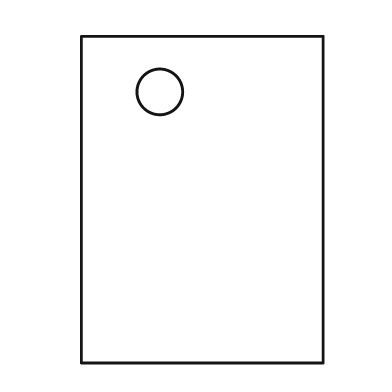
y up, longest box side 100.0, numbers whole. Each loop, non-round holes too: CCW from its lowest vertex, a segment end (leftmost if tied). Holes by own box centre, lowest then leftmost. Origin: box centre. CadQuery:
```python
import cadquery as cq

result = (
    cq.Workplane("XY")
    .moveTo(-37.0, -50.0)
    .lineTo(37.0, -50.0)
    .lineTo(37.0, 50.0)
    .lineTo(-37.0, 50.0)
    .close()
    .moveTo(-13.0, 33.0)
    .circle(7.0)
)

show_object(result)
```